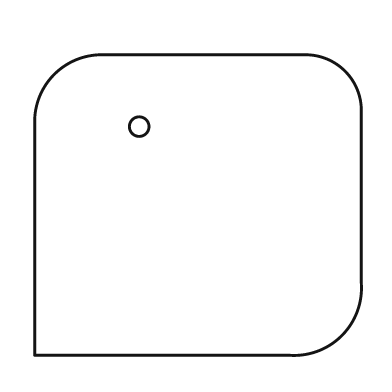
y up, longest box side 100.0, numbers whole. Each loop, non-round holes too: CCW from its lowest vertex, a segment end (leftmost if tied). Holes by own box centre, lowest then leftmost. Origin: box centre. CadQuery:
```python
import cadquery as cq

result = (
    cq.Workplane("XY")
    .moveTo(-50.0, -46.0)
    .lineTo(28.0, -46.0)
    .threePointArc((44.0, -40.0), (50.0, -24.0))
    .lineTo(50.0, 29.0)
    .threePointArc((45.0, 41.0), (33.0, 46.0))
    .lineTo(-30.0, 46.0)
    .threePointArc((-44.0, 40.0), (-50.0, 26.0))
    .close()
    .moveTo(-18.0, 24.0)
    .circle(3.0)
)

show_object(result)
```